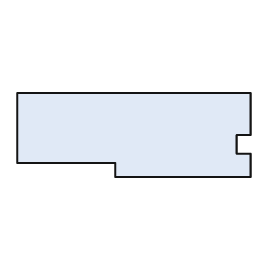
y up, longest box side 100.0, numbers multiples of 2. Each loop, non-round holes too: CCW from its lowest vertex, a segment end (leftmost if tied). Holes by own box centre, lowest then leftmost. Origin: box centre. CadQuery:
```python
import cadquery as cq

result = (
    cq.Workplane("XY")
    .moveTo(-8.0, -18.0)
    .lineTo(50.0, -18.0)
    .lineTo(50.0, -8.0)
    .lineTo(44.0, -8.0)
    .lineTo(44.0, 0.0)
    .lineTo(50.0, 0.0)
    .lineTo(50.0, 18.0)
    .lineTo(-50.0, 18.0)
    .lineTo(-50.0, -12.0)
    .lineTo(-8.0, -12.0)
    .close()
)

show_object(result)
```